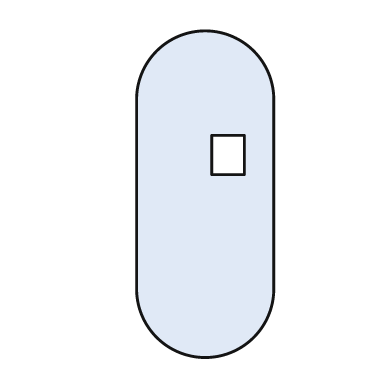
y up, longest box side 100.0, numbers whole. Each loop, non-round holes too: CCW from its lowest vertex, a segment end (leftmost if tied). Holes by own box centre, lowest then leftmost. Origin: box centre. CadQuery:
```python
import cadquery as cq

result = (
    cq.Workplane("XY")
    .moveTo(-21.0, -29.0)
    .threePointArc((0.0, -50.0), (21.0, -29.0))
    .lineTo(21.0, 29.0)
    .threePointArc((0.0, 50.0), (-21.0, 29.0))
    .close()
    .moveTo(2.0, 6.0)
    .lineTo(12.0, 6.0)
    .lineTo(12.0, 18.0)
    .lineTo(2.0, 18.0)
    .close()
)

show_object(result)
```